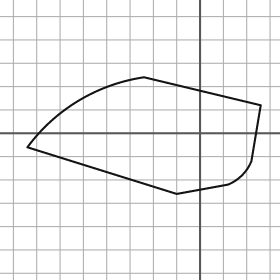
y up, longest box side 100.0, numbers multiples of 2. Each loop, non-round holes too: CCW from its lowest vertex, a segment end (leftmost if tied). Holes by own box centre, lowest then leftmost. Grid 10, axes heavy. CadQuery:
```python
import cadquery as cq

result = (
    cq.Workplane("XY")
    .moveTo(-10.0, -26.0)
    .lineTo(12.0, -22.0)
    .threePointArc((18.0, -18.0), (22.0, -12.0))
    .lineTo(26.0, 12.0)
    .lineTo(-24.0, 24.0)
    .threePointArc((-52.0, 14.0), (-74.0, -6.0))
    .close()
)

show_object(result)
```